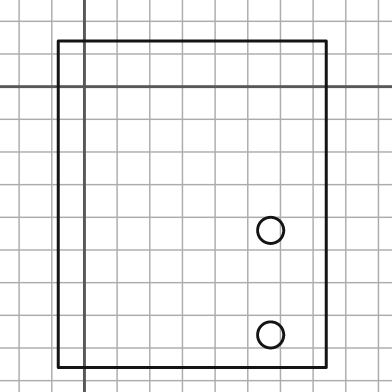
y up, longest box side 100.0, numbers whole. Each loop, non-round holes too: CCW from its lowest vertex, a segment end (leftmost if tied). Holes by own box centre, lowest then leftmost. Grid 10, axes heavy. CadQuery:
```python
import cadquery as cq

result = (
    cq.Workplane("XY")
    .moveTo(-8.0, -86.0)
    .lineTo(74.0, -86.0)
    .lineTo(74.0, 14.0)
    .lineTo(-8.0, 14.0)
    .close()
    .moveTo(57.0, -76.0)
    .circle(4.0)
    .moveTo(57.0, -44.0)
    .circle(4.0)
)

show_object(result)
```